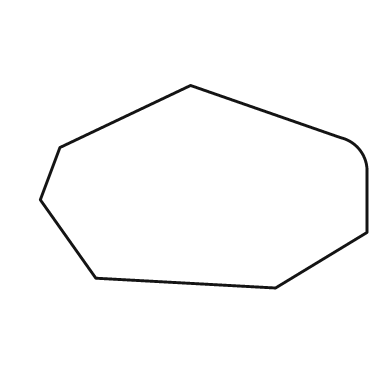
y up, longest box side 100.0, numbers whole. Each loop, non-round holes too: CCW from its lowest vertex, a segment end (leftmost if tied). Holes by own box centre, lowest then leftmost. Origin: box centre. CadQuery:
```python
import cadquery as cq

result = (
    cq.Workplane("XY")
    .moveTo(22.0, -31.0)
    .lineTo(50.0, -14.0)
    .lineTo(50.0, 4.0)
    .threePointArc((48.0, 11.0), (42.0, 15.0))
    .lineTo(-4.0, 31.0)
    .lineTo(-44.0, 12.0)
    .lineTo(-50.0, -4.0)
    .lineTo(-33.0, -28.0)
    .close()
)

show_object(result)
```